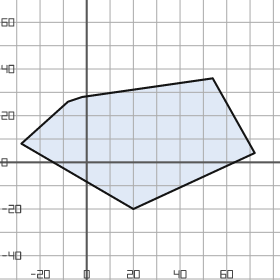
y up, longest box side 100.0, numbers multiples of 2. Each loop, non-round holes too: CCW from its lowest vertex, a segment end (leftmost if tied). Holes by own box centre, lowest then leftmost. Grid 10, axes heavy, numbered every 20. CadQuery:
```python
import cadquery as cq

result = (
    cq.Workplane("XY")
    .moveTo(20.0, -20.0)
    .lineTo(72.0, 4.0)
    .lineTo(54.0, 36.0)
    .lineTo(-2.0, 28.0)
    .lineTo(-8.0, 26.0)
    .lineTo(-28.0, 8.0)
    .close()
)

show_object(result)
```